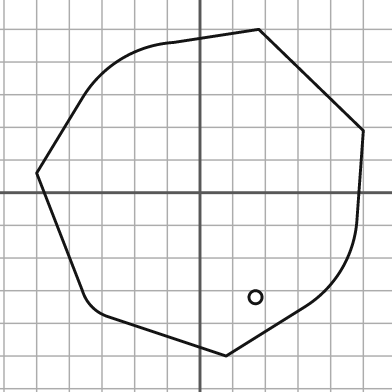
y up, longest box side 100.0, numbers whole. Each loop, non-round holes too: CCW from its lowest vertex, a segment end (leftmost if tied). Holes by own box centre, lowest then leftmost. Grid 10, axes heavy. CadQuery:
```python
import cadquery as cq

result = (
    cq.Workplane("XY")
    .moveTo(8.0, -50.0)
    .lineTo(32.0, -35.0)
    .threePointArc((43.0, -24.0), (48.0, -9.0))
    .lineTo(50.0, 19.0)
    .lineTo(18.0, 50.0)
    .lineTo(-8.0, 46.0)
    .threePointArc((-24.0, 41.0), (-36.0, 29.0))
    .lineTo(-50.0, 6.0)
    .lineTo(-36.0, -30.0)
    .threePointArc((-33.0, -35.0), (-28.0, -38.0))
    .close()
    .moveTo(17.0, -32.0)
    .circle(2.0)
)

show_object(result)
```